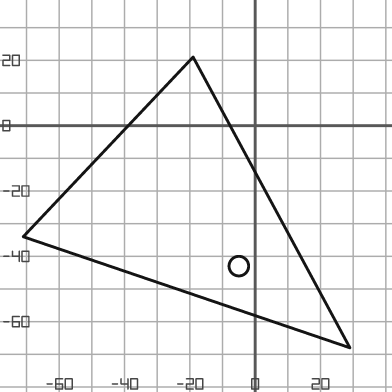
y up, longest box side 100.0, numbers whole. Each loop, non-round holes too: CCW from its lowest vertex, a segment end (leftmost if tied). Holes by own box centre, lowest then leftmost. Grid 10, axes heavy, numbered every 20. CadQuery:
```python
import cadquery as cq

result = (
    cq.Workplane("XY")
    .moveTo(29.0, -68.0)
    .lineTo(-19.0, 21.0)
    .lineTo(-71.0, -34.0)
    .close()
    .moveTo(-5.0, -43.0)
    .circle(3.0)
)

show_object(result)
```